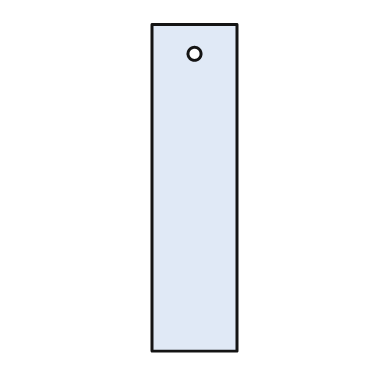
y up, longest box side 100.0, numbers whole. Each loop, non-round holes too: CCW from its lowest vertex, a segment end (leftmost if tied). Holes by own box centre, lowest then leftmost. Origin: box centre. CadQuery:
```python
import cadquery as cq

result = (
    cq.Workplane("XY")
    .moveTo(-13.0, -50.0)
    .lineTo(13.0, -50.0)
    .lineTo(13.0, 50.0)
    .lineTo(-13.0, 50.0)
    .close()
    .moveTo(0.0, 41.0)
    .circle(2.0)
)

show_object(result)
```